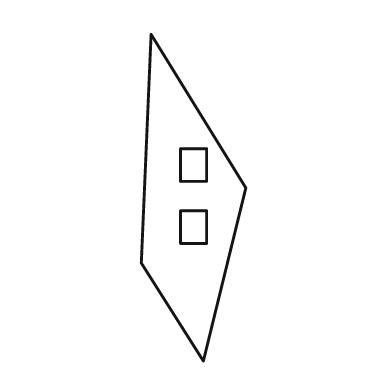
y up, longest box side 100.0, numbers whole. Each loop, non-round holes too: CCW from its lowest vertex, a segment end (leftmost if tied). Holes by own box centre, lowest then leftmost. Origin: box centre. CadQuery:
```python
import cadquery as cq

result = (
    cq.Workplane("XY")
    .moveTo(3.0, -50.0)
    .lineTo(16.0, 3.0)
    .lineTo(-13.0, 50.0)
    .lineTo(-16.0, -20.0)
    .close()
    .moveTo(-4.0, -14.0)
    .lineTo(4.0, -14.0)
    .lineTo(4.0, -4.0)
    .lineTo(-4.0, -4.0)
    .close()
    .moveTo(-4.0, 5.0)
    .lineTo(4.0, 5.0)
    .lineTo(4.0, 15.0)
    .lineTo(-4.0, 15.0)
    .close()
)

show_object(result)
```